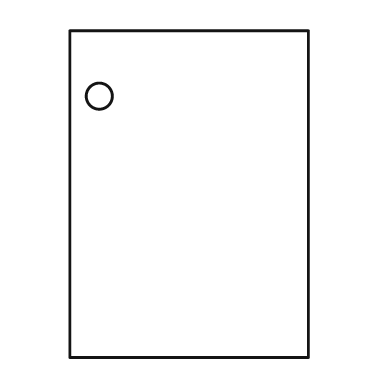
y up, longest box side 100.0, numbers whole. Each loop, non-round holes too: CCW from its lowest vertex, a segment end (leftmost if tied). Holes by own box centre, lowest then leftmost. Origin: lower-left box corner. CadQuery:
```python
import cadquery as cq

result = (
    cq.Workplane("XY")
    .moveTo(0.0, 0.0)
    .lineTo(73.0, 0.0)
    .lineTo(73.0, 100.0)
    .lineTo(0.0, 100.0)
    .close()
    .moveTo(9.0, 80.0)
    .circle(4.0)
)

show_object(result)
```